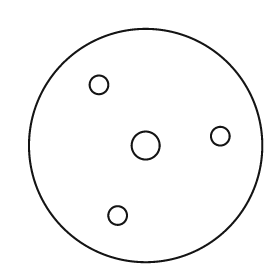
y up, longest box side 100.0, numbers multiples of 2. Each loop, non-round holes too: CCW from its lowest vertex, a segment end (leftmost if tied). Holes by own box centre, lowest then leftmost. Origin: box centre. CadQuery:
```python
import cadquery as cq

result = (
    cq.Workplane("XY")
    .moveTo(0.0, 0.0)
    .circle(50.0)
    .moveTo(-12.0, -30.0)
    .circle(4.0)
    .moveTo(0.0, 0.0)
    .circle(6.0)
    .moveTo(32.0, 4.0)
    .circle(4.0)
    .moveTo(-20.0, 26.0)
    .circle(4.0)
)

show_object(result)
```